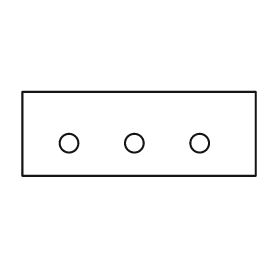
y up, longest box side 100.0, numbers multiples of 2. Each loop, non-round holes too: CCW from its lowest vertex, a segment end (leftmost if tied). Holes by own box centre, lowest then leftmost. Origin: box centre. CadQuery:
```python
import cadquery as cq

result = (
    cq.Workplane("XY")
    .moveTo(-50.0, -18.0)
    .lineTo(50.0, -18.0)
    .lineTo(50.0, 18.0)
    .lineTo(-50.0, 18.0)
    .close()
    .moveTo(-30.0, -4.0)
    .circle(4.0)
    .moveTo(-2.0, -4.0)
    .circle(4.0)
    .moveTo(26.0, -4.0)
    .circle(4.0)
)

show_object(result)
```